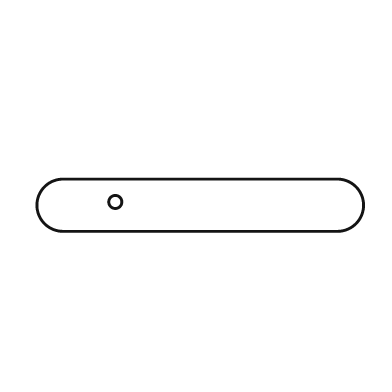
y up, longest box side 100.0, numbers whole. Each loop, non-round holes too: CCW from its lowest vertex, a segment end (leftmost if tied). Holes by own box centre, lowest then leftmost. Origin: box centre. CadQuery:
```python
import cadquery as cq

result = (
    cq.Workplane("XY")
    .moveTo(-42.0, -8.0)
    .lineTo(42.0, -8.0)
    .threePointArc((50.0, 0.0), (42.0, 8.0))
    .lineTo(-42.0, 8.0)
    .threePointArc((-50.0, 0.0), (-42.0, -8.0))
    .close()
    .moveTo(-26.0, 1.0)
    .circle(2.0)
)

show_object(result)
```